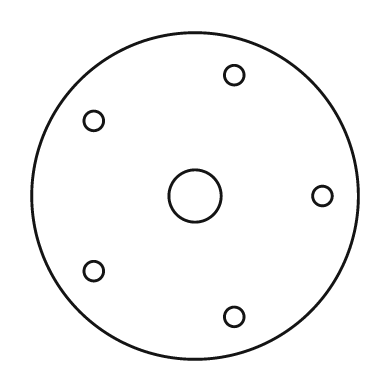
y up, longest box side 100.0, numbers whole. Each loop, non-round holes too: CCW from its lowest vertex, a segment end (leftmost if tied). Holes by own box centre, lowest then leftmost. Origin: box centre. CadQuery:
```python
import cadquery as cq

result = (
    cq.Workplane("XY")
    .moveTo(0.0, 0.0)
    .circle(50.0)
    .moveTo(12.0, -37.0)
    .circle(3.0)
    .moveTo(-31.0, -23.0)
    .circle(3.0)
    .moveTo(0.0, 0.0)
    .circle(8.0)
    .moveTo(39.0, 0.0)
    .circle(3.0)
    .moveTo(-31.0, 23.0)
    .circle(3.0)
    .moveTo(12.0, 37.0)
    .circle(3.0)
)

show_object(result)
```